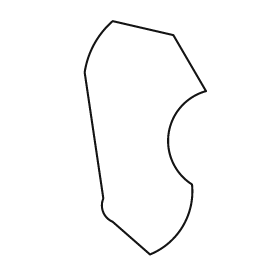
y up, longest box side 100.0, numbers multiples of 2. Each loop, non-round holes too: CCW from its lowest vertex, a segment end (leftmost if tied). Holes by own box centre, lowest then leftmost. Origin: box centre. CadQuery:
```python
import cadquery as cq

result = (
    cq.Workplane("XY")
    .moveTo(2.0, -50.0)
    .threePointArc((16.0, -38.0), (20.0, -20.0))
    .threePointArc((10.0, 2.0), (26.0, 20.0))
    .lineTo(12.0, 44.0)
    .lineTo(-14.0, 50.0)
    .threePointArc((-22.0, 40.0), (-26.0, 28.0))
    .lineTo(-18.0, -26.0)
    .threePointArc((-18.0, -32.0), (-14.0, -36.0))
    .close()
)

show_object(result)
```